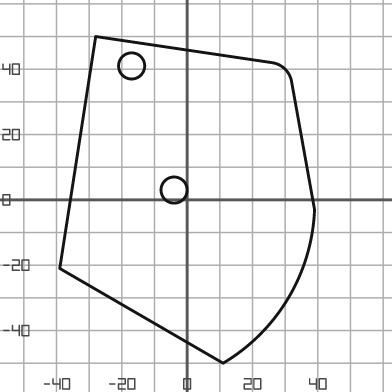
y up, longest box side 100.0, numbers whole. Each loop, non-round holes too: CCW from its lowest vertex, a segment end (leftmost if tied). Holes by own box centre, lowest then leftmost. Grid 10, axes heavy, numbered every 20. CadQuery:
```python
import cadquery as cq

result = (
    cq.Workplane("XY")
    .moveTo(11.0, -50.0)
    .threePointArc((31.0, -30.0), (39.0, -3.0))
    .lineTo(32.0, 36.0)
    .threePointArc((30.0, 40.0), (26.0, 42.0))
    .lineTo(-28.0, 50.0)
    .lineTo(-39.0, -21.0)
    .close()
    .moveTo(-4.0, 3.0)
    .circle(4.0)
    .moveTo(-17.0, 41.0)
    .circle(4.0)
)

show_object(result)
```